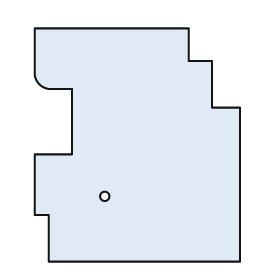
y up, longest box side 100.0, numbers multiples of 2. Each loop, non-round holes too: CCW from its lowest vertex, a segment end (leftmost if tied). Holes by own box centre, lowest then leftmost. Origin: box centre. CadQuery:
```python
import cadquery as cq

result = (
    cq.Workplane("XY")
    .moveTo(-38.0, -50.0)
    .lineTo(44.0, -50.0)
    .lineTo(44.0, 16.0)
    .lineTo(32.0, 16.0)
    .lineTo(32.0, 36.0)
    .lineTo(22.0, 36.0)
    .lineTo(22.0, 50.0)
    .lineTo(-44.0, 50.0)
    .lineTo(-44.0, 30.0)
    .threePointArc((-42.0, 26.0), (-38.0, 24.0))
    .lineTo(-28.0, 24.0)
    .lineTo(-28.0, -4.0)
    .lineTo(-44.0, -4.0)
    .lineTo(-44.0, -30.0)
    .lineTo(-38.0, -30.0)
    .close()
    .moveTo(-14.0, -22.0)
    .circle(2.0)
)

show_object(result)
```